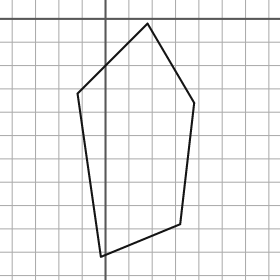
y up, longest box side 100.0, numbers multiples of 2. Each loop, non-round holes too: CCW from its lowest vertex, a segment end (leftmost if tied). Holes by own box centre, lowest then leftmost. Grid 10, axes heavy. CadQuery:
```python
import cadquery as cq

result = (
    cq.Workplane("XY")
    .moveTo(-2.0, -102.0)
    .lineTo(32.0, -88.0)
    .lineTo(38.0, -36.0)
    .lineTo(18.0, -2.0)
    .lineTo(-12.0, -32.0)
    .close()
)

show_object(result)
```